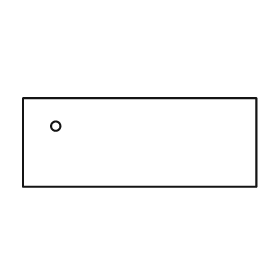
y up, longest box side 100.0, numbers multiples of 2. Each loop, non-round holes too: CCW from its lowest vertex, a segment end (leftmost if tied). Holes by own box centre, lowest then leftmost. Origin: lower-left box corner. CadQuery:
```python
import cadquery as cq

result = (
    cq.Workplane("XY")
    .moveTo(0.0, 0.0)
    .lineTo(100.0, 0.0)
    .lineTo(100.0, 38.0)
    .lineTo(0.0, 38.0)
    .close()
    .moveTo(14.0, 26.0)
    .circle(2.0)
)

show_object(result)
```